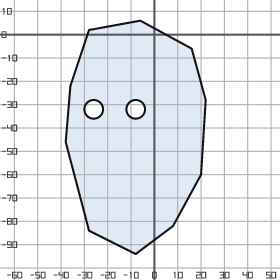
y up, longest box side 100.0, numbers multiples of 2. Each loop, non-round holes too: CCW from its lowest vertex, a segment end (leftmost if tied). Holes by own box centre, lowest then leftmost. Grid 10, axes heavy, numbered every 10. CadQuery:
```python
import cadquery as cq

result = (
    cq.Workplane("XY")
    .moveTo(-8.0, -94.0)
    .lineTo(8.0, -82.0)
    .lineTo(20.0, -60.0)
    .lineTo(22.0, -28.0)
    .lineTo(16.0, -6.0)
    .lineTo(-6.0, 6.0)
    .lineTo(-28.0, 2.0)
    .lineTo(-36.0, -22.0)
    .lineTo(-38.0, -46.0)
    .lineTo(-28.0, -84.0)
    .close()
    .moveTo(-26.0, -32.0)
    .circle(4.0)
    .moveTo(-8.0, -32.0)
    .circle(4.0)
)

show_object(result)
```